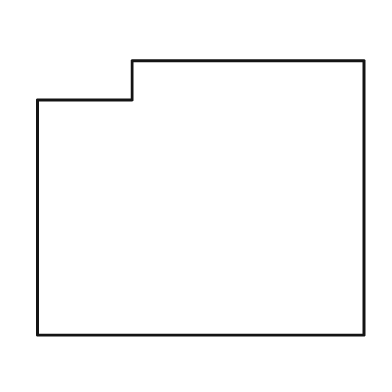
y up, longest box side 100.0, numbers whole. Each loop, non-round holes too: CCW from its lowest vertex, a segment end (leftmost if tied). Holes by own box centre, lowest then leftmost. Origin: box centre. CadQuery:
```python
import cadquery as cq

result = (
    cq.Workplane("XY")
    .moveTo(-50.0, -42.0)
    .lineTo(50.0, -42.0)
    .lineTo(50.0, 42.0)
    .lineTo(-21.0, 42.0)
    .lineTo(-21.0, 30.0)
    .lineTo(-50.0, 30.0)
    .close()
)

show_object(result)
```